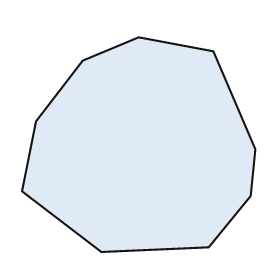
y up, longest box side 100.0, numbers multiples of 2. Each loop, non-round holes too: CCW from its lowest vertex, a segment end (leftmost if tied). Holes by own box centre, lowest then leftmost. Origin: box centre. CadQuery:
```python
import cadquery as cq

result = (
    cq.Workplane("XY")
    .moveTo(-16.0, -46.0)
    .lineTo(30.0, -44.0)
    .lineTo(48.0, -22.0)
    .lineTo(50.0, -2.0)
    .lineTo(32.0, 40.0)
    .lineTo(0.0, 46.0)
    .lineTo(-24.0, 36.0)
    .lineTo(-44.0, 10.0)
    .lineTo(-50.0, -20.0)
    .close()
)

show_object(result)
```